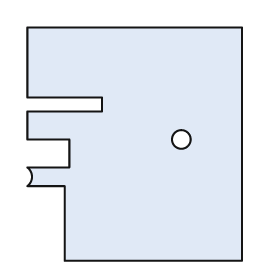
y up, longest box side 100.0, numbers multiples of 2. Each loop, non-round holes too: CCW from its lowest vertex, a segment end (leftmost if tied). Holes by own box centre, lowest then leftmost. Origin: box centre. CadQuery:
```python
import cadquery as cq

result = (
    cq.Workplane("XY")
    .moveTo(-30.0, -50.0)
    .lineTo(46.0, -50.0)
    .lineTo(46.0, 50.0)
    .lineTo(-46.0, 50.0)
    .lineTo(-46.0, 20.0)
    .lineTo(-14.0, 20.0)
    .lineTo(-14.0, 14.0)
    .lineTo(-46.0, 14.0)
    .lineTo(-46.0, 2.0)
    .lineTo(-28.0, 2.0)
    .lineTo(-28.0, -10.0)
    .lineTo(-46.0, -10.0)
    .threePointArc((-44.0, -14.0), (-46.0, -18.0))
    .lineTo(-30.0, -18.0)
    .close()
    .moveTo(20.0, 2.0)
    .circle(4.0)
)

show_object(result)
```